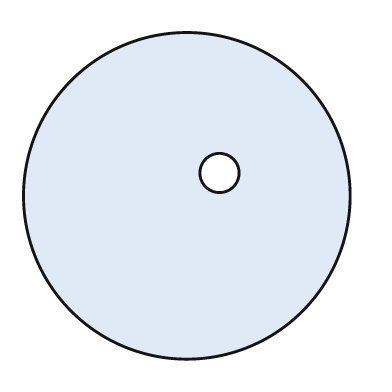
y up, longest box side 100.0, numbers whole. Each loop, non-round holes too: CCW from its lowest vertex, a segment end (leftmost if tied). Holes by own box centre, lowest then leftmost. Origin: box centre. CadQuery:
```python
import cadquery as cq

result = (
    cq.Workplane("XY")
    .moveTo(0.0, 0.0)
    .circle(50.0)
    .moveTo(10.0, 7.0)
    .circle(6.0)
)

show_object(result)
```